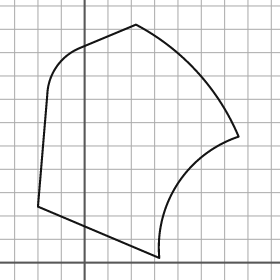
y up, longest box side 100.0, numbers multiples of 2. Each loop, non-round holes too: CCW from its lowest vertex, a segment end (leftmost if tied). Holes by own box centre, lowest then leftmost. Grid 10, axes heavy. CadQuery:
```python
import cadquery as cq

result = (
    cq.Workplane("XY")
    .moveTo(32.0, 2.0)
    .threePointArc((40.0, 34.0), (66.0, 54.0))
    .threePointArc((48.0, 82.0), (22.0, 102.0))
    .lineTo(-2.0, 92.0)
    .threePointArc((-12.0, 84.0), (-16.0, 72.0))
    .lineTo(-20.0, 24.0)
    .close()
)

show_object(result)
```